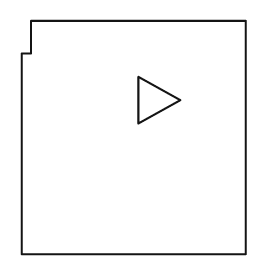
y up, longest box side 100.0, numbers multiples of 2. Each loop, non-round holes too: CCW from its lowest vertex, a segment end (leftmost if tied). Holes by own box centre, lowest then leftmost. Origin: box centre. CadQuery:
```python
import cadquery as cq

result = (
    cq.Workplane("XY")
    .moveTo(-48.0, -50.0)
    .lineTo(48.0, -50.0)
    .lineTo(48.0, 50.0)
    .lineTo(-44.0, 50.0)
    .lineTo(-44.0, 36.0)
    .lineTo(-48.0, 36.0)
    .close()
    .moveTo(2.0, 6.0)
    .lineTo(20.0, 16.0)
    .lineTo(2.0, 26.0)
    .close()
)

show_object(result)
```